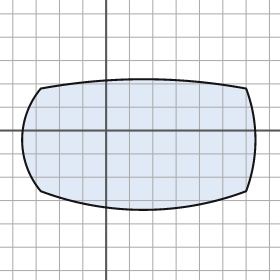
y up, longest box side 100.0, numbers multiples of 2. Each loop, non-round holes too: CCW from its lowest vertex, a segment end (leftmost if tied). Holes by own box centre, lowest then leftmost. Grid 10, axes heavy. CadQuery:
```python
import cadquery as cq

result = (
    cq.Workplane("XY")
    .moveTo(-28.0, -26.0)
    .threePointArc((16.0, -34.0), (60.0, -26.0))
    .threePointArc((64.0, -4.0), (60.0, 18.0))
    .threePointArc((16.0, 22.0), (-28.0, 18.0))
    .threePointArc((-36.0, -4.0), (-28.0, -26.0))
    .close()
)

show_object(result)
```